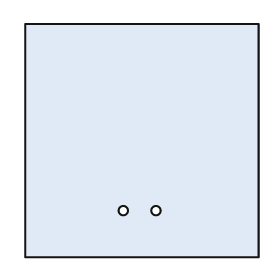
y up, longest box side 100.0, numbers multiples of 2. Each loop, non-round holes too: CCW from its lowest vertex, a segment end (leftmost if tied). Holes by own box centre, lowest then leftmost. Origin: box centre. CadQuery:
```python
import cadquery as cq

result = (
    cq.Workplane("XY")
    .moveTo(-50.0, -50.0)
    .lineTo(50.0, -50.0)
    .lineTo(50.0, 50.0)
    .lineTo(-50.0, 50.0)
    .close()
    .moveTo(-8.0, -30.0)
    .circle(2.0)
    .moveTo(6.0, -30.0)
    .circle(2.0)
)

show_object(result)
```